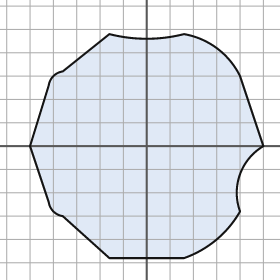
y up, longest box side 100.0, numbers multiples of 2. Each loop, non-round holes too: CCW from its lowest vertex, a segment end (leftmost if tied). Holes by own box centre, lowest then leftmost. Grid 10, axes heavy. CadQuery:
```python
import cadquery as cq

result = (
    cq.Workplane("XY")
    .moveTo(-16.0, -48.0)
    .lineTo(16.0, -48.0)
    .threePointArc((30.0, -40.0), (40.0, -28.0))
    .threePointArc((40.0, -12.0), (50.0, 0.0))
    .lineTo(40.0, 30.0)
    .threePointArc((30.0, 42.0), (16.0, 48.0))
    .threePointArc((0.0, 46.0), (-16.0, 48.0))
    .lineTo(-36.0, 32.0)
    .threePointArc((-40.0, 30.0), (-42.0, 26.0))
    .lineTo(-50.0, 0.0)
    .lineTo(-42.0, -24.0)
    .threePointArc((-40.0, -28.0), (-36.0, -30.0))
    .close()
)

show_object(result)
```